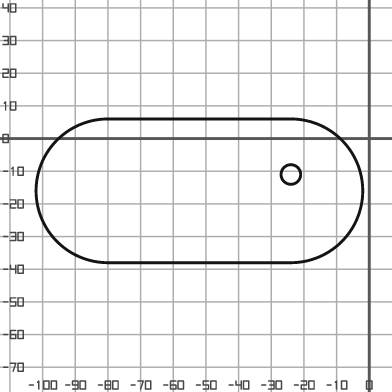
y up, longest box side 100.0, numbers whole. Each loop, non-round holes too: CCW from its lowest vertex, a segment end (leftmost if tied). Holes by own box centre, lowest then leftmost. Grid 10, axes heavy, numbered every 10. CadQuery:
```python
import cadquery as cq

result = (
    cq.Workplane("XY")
    .moveTo(-80.0, -38.0)
    .lineTo(-24.0, -38.0)
    .threePointArc((-2.0, -16.0), (-24.0, 6.0))
    .lineTo(-80.0, 6.0)
    .threePointArc((-102.0, -16.0), (-80.0, -38.0))
    .close()
    .moveTo(-24.0, -11.0)
    .circle(3.0)
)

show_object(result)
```